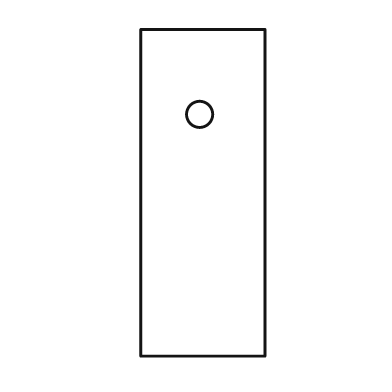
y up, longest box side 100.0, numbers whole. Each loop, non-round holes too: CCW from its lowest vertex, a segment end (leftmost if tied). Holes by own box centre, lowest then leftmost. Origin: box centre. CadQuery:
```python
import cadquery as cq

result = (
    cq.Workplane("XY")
    .moveTo(-19.0, -50.0)
    .lineTo(19.0, -50.0)
    .lineTo(19.0, 50.0)
    .lineTo(-19.0, 50.0)
    .close()
    .moveTo(-1.0, 24.0)
    .circle(4.0)
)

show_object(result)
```